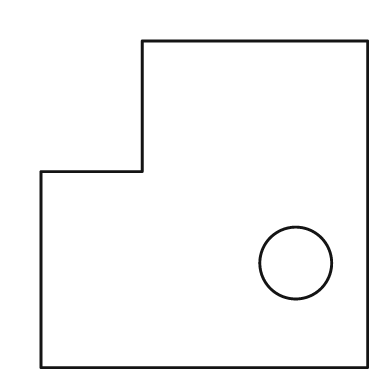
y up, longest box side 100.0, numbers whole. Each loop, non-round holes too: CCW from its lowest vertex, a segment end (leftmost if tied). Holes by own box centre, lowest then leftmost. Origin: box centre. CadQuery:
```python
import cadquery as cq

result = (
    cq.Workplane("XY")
    .moveTo(-50.0, -50.0)
    .lineTo(50.0, -50.0)
    .lineTo(50.0, 50.0)
    .lineTo(-19.0, 50.0)
    .lineTo(-19.0, 10.0)
    .lineTo(-50.0, 10.0)
    .close()
    .moveTo(28.0, -18.0)
    .circle(11.0)
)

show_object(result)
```